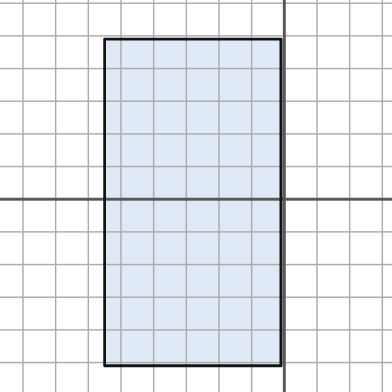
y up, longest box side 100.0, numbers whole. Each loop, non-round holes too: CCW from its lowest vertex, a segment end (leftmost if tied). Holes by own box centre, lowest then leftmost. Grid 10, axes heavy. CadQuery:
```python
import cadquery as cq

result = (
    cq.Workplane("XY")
    .moveTo(-55.0, -51.0)
    .lineTo(-1.0, -51.0)
    .lineTo(-1.0, 49.0)
    .lineTo(-55.0, 49.0)
    .close()
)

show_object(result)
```